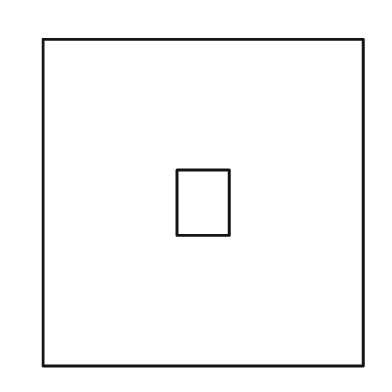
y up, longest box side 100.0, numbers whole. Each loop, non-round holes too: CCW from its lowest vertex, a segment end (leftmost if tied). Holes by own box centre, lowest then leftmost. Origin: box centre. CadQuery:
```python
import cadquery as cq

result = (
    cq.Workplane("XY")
    .moveTo(-49.0, -50.0)
    .lineTo(49.0, -50.0)
    .lineTo(49.0, 50.0)
    .lineTo(-49.0, 50.0)
    .close()
    .moveTo(-8.0, -10.0)
    .lineTo(8.0, -10.0)
    .lineTo(8.0, 10.0)
    .lineTo(-8.0, 10.0)
    .close()
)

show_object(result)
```